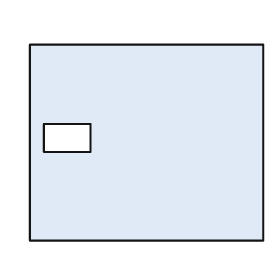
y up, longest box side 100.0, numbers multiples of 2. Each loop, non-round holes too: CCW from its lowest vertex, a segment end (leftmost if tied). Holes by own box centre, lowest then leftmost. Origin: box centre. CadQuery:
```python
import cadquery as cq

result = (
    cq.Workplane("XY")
    .moveTo(-50.0, -42.0)
    .lineTo(50.0, -42.0)
    .lineTo(50.0, 42.0)
    .lineTo(-50.0, 42.0)
    .close()
    .moveTo(-44.0, -4.0)
    .lineTo(-24.0, -4.0)
    .lineTo(-24.0, 8.0)
    .lineTo(-44.0, 8.0)
    .close()
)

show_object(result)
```